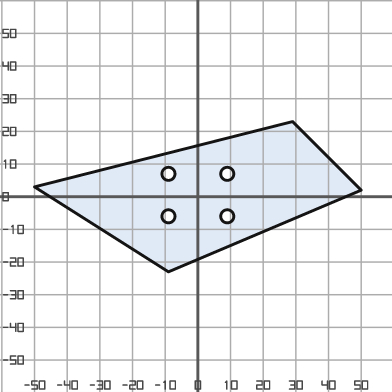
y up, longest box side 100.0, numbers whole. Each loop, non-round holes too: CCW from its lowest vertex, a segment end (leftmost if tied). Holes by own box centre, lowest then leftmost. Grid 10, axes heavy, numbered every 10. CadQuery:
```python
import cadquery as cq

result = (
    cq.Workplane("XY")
    .moveTo(-9.0, -23.0)
    .lineTo(50.0, 2.0)
    .lineTo(29.0, 23.0)
    .lineTo(-50.0, 3.0)
    .close()
    .moveTo(-9.0, -6.0)
    .circle(2.0)
    .moveTo(9.0, -6.0)
    .circle(2.0)
    .moveTo(-9.0, 7.0)
    .circle(2.0)
    .moveTo(9.0, 7.0)
    .circle(2.0)
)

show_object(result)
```